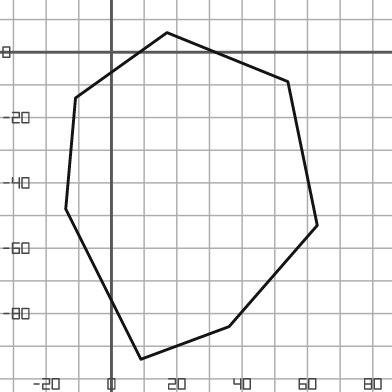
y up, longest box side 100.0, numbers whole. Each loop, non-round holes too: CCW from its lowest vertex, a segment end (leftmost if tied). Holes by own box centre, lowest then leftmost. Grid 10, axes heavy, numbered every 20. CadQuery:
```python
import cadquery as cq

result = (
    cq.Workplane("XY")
    .moveTo(9.0, -94.0)
    .lineTo(36.0, -84.0)
    .lineTo(63.0, -53.0)
    .lineTo(54.0, -9.0)
    .lineTo(17.0, 6.0)
    .lineTo(-11.0, -14.0)
    .lineTo(-14.0, -48.0)
    .close()
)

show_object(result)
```